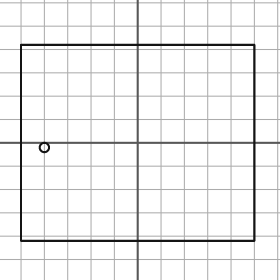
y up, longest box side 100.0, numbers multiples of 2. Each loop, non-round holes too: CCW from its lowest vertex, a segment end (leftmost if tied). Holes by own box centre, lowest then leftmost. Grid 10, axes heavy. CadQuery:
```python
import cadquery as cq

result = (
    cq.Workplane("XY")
    .moveTo(-50.0, -42.0)
    .lineTo(50.0, -42.0)
    .lineTo(50.0, 42.0)
    .lineTo(-50.0, 42.0)
    .close()
    .moveTo(-40.0, -2.0)
    .circle(2.0)
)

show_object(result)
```